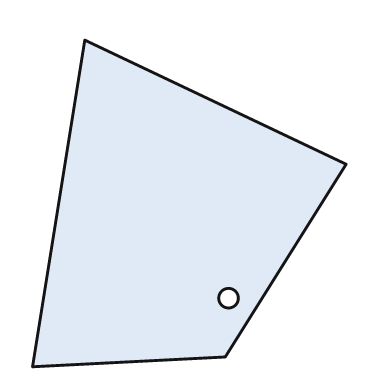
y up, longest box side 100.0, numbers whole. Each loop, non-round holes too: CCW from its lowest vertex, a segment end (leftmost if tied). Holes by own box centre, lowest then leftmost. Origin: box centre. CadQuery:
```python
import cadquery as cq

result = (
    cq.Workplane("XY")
    .moveTo(-48.0, -50.0)
    .lineTo(11.0, -47.0)
    .lineTo(48.0, 12.0)
    .lineTo(-32.0, 50.0)
    .close()
    .moveTo(12.0, -29.0)
    .circle(3.0)
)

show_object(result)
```